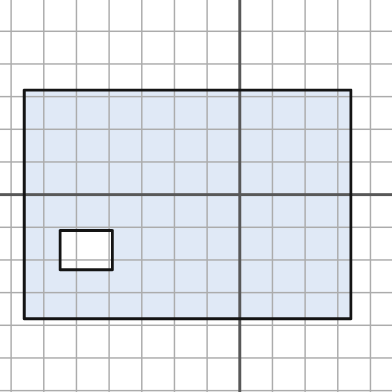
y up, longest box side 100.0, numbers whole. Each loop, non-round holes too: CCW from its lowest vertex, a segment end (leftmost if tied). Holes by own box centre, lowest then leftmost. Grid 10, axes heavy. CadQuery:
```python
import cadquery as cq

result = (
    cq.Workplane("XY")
    .moveTo(-66.0, -38.0)
    .lineTo(34.0, -38.0)
    .lineTo(34.0, 32.0)
    .lineTo(-66.0, 32.0)
    .close()
    .moveTo(-55.0, -23.0)
    .lineTo(-39.0, -23.0)
    .lineTo(-39.0, -11.0)
    .lineTo(-55.0, -11.0)
    .close()
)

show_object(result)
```